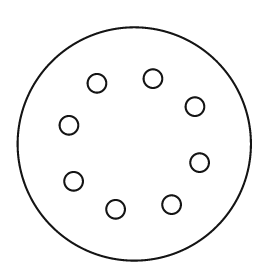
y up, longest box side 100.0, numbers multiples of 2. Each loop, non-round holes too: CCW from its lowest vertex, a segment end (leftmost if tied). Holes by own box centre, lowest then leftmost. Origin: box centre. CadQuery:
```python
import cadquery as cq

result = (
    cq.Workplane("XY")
    .moveTo(0.0, 0.0)
    .circle(50.0)
    .moveTo(-8.0, -28.0)
    .circle(4.0)
    .moveTo(16.0, -26.0)
    .circle(4.0)
    .moveTo(-26.0, -16.0)
    .circle(4.0)
    .moveTo(28.0, -8.0)
    .circle(4.0)
    .moveTo(-28.0, 8.0)
    .circle(4.0)
    .moveTo(26.0, 16.0)
    .circle(4.0)
    .moveTo(-16.0, 26.0)
    .circle(4.0)
    .moveTo(8.0, 28.0)
    .circle(4.0)
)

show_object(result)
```